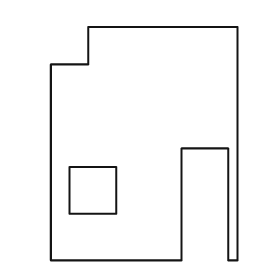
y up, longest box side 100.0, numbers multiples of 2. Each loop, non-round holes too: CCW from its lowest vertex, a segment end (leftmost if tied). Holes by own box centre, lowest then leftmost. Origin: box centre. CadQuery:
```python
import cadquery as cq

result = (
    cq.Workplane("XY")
    .moveTo(-40.0, -50.0)
    .lineTo(16.0, -50.0)
    .lineTo(16.0, -2.0)
    .lineTo(36.0, -2.0)
    .lineTo(36.0, -50.0)
    .lineTo(40.0, -50.0)
    .lineTo(40.0, 50.0)
    .lineTo(-24.0, 50.0)
    .lineTo(-24.0, 34.0)
    .lineTo(-40.0, 34.0)
    .close()
    .moveTo(-32.0, -30.0)
    .lineTo(-12.0, -30.0)
    .lineTo(-12.0, -10.0)
    .lineTo(-32.0, -10.0)
    .close()
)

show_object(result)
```